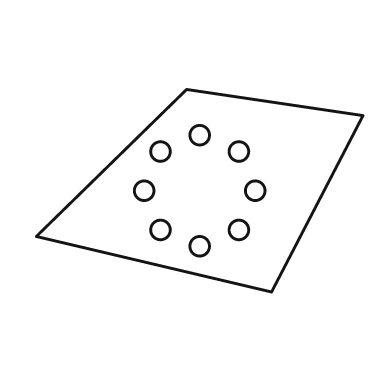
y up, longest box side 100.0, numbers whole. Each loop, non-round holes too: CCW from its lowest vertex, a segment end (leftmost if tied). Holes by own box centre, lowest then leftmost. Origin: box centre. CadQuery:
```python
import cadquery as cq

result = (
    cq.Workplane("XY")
    .moveTo(22.0, -31.0)
    .lineTo(50.0, 23.0)
    .lineTo(-4.0, 31.0)
    .lineTo(-50.0, -14.0)
    .close()
    .moveTo(0.0, -17.0)
    .circle(3.0)
    .moveTo(-12.0, -12.0)
    .circle(3.0)
    .moveTo(12.0, -12.0)
    .circle(3.0)
    .moveTo(-17.0, 0.0)
    .circle(3.0)
    .moveTo(17.0, 0.0)
    .circle(3.0)
    .moveTo(-12.0, 12.0)
    .circle(3.0)
    .moveTo(12.0, 12.0)
    .circle(3.0)
    .moveTo(0.0, 17.0)
    .circle(3.0)
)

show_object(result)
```